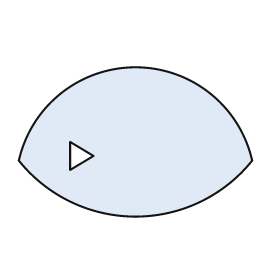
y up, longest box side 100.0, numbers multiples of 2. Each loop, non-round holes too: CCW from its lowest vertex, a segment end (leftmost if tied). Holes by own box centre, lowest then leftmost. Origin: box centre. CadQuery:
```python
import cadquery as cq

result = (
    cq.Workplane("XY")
    .moveTo(-50.0, -8.0)
    .threePointArc((0.0, -32.0), (50.0, -8.0))
    .threePointArc((0.0, 32.0), (-50.0, -8.0))
    .close()
    .moveTo(-28.0, -12.0)
    .lineTo(-18.0, -6.0)
    .lineTo(-28.0, 0.0)
    .close()
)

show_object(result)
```